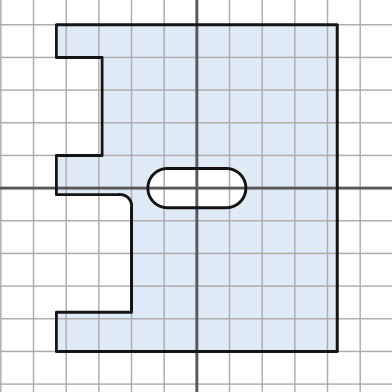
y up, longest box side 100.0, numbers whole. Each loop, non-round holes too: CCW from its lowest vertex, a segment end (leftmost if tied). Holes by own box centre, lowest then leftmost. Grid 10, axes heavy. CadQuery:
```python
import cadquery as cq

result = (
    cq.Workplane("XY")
    .moveTo(-43.0, -50.0)
    .lineTo(43.0, -50.0)
    .lineTo(43.0, 50.0)
    .lineTo(-43.0, 50.0)
    .lineTo(-43.0, 40.0)
    .lineTo(-29.0, 40.0)
    .lineTo(-29.0, 10.0)
    .lineTo(-43.0, 10.0)
    .lineTo(-43.0, -2.0)
    .lineTo(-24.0, -2.0)
    .threePointArc((-21.0, -3.0), (-20.0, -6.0))
    .lineTo(-20.0, -38.0)
    .lineTo(-43.0, -38.0)
    .close()
    .moveTo(-9.0, -6.0)
    .lineTo(9.0, -6.0)
    .threePointArc((15.0, 0.0), (9.0, 6.0))
    .lineTo(-9.0, 6.0)
    .threePointArc((-15.0, 0.0), (-9.0, -6.0))
    .close()
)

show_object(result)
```